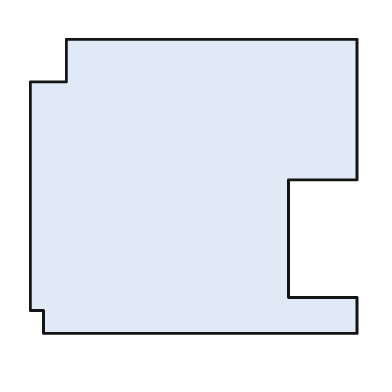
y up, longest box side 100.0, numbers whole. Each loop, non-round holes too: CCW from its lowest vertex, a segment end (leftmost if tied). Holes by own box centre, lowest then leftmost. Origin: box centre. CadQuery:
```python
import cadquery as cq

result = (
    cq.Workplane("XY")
    .moveTo(-46.0, -45.0)
    .lineTo(50.0, -45.0)
    .lineTo(50.0, -34.0)
    .lineTo(29.0, -34.0)
    .lineTo(29.0, 2.0)
    .lineTo(50.0, 2.0)
    .lineTo(50.0, 45.0)
    .lineTo(-39.0, 45.0)
    .lineTo(-39.0, 32.0)
    .lineTo(-50.0, 32.0)
    .lineTo(-50.0, -38.0)
    .lineTo(-46.0, -38.0)
    .close()
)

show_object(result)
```